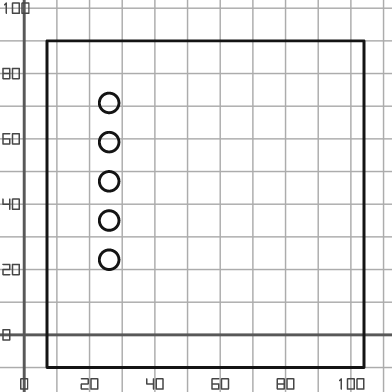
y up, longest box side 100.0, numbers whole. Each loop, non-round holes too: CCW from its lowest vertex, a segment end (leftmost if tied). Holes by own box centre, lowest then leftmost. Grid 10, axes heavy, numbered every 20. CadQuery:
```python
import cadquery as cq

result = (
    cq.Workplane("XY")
    .moveTo(7.0, -10.0)
    .lineTo(104.0, -10.0)
    .lineTo(104.0, 90.0)
    .lineTo(7.0, 90.0)
    .close()
    .moveTo(26.0, 23.0)
    .circle(3.0)
    .moveTo(26.0, 35.0)
    .circle(3.0)
    .moveTo(26.0, 47.0)
    .circle(3.0)
    .moveTo(26.0, 59.0)
    .circle(3.0)
    .moveTo(26.0, 71.0)
    .circle(3.0)
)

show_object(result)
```